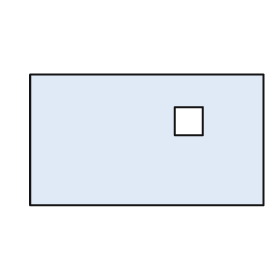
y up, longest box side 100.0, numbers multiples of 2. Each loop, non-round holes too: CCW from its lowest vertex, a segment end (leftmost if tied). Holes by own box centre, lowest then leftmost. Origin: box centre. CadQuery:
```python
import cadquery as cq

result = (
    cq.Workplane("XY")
    .moveTo(-50.0, -28.0)
    .lineTo(50.0, -28.0)
    .lineTo(50.0, 28.0)
    .lineTo(-50.0, 28.0)
    .close()
    .moveTo(12.0, 2.0)
    .lineTo(24.0, 2.0)
    .lineTo(24.0, 14.0)
    .lineTo(12.0, 14.0)
    .close()
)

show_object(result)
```